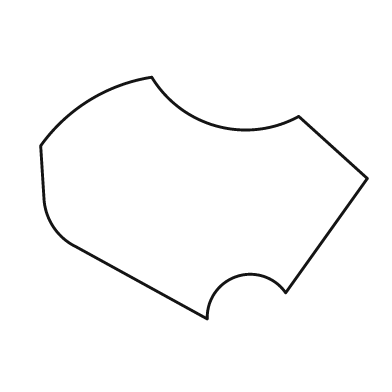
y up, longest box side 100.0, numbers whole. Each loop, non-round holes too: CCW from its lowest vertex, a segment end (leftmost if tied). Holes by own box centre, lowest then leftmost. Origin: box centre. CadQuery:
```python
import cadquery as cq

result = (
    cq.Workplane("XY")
    .moveTo(1.0, -37.0)
    .threePointArc((10.0, -24.0), (25.0, -29.0))
    .lineTo(50.0, 6.0)
    .lineTo(29.0, 25.0)
    .threePointArc((4.0, 22.0), (-16.0, 37.0))
    .threePointArc((-35.0, 30.0), (-50.0, 16.0))
    .lineTo(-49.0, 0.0)
    .threePointArc((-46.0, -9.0), (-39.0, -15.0))
    .close()
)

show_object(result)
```